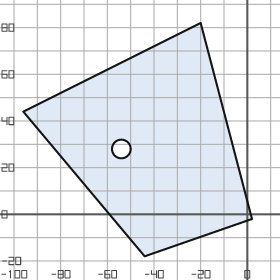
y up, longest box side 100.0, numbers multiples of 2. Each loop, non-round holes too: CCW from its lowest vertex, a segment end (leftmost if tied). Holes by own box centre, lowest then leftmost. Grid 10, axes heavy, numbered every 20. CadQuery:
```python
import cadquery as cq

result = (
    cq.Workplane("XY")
    .moveTo(-44.0, -18.0)
    .lineTo(2.0, -2.0)
    .lineTo(-20.0, 82.0)
    .lineTo(-96.0, 44.0)
    .close()
    .moveTo(-54.0, 28.0)
    .circle(4.0)
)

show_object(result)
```